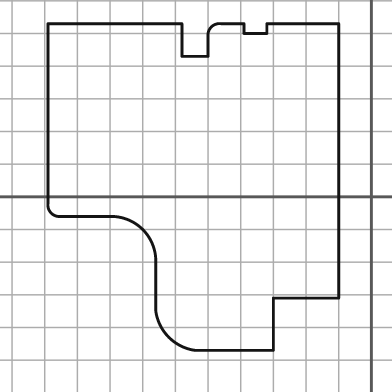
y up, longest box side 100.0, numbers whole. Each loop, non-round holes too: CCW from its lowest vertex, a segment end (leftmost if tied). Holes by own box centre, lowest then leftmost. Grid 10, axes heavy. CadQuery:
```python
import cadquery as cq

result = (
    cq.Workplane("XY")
    .moveTo(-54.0, -47.0)
    .lineTo(-30.0, -47.0)
    .lineTo(-30.0, -31.0)
    .lineTo(-10.0, -31.0)
    .lineTo(-10.0, 53.0)
    .lineTo(-32.0, 53.0)
    .lineTo(-32.0, 50.0)
    .lineTo(-39.0, 50.0)
    .lineTo(-39.0, 53.0)
    .lineTo(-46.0, 53.0)
    .threePointArc((-49.0, 52.0), (-50.0, 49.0))
    .lineTo(-50.0, 43.0)
    .lineTo(-58.0, 43.0)
    .lineTo(-58.0, 53.0)
    .lineTo(-99.0, 53.0)
    .lineTo(-99.0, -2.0)
    .threePointArc((-98.0, -5.0), (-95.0, -6.0))
    .lineTo(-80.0, -6.0)
    .threePointArc((-70.0, -10.0), (-66.0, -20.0))
    .lineTo(-66.0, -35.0)
    .threePointArc((-62.0, -43.0), (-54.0, -47.0))
    .close()
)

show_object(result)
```